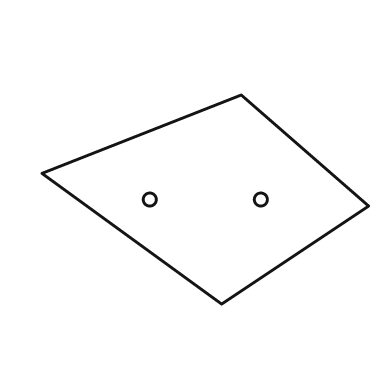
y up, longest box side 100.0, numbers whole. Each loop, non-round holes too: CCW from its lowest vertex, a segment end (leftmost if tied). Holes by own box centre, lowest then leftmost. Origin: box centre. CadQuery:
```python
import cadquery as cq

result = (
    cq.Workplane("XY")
    .moveTo(5.0, -32.0)
    .lineTo(50.0, -2.0)
    .lineTo(11.0, 32.0)
    .lineTo(-50.0, 8.0)
    .close()
    .moveTo(-17.0, 0.0)
    .circle(2.0)
    .moveTo(17.0, 0.0)
    .circle(2.0)
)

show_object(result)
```